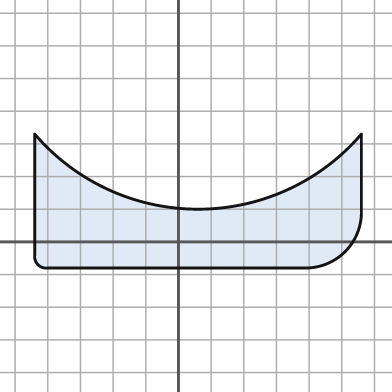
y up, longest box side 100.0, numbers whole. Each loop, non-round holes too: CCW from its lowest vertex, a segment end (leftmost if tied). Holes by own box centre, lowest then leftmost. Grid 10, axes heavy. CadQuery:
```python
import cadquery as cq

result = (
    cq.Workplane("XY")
    .moveTo(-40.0, -8.0)
    .lineTo(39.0, -8.0)
    .threePointArc((51.0, -3.0), (56.0, 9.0))
    .lineTo(56.0, 33.0)
    .threePointArc((6.0, 10.0), (-44.0, 33.0))
    .lineTo(-44.0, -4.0)
    .threePointArc((-43.0, -7.0), (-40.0, -8.0))
    .close()
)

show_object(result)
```